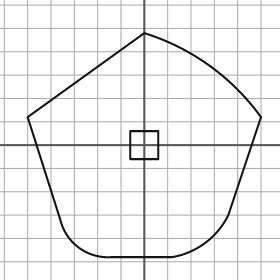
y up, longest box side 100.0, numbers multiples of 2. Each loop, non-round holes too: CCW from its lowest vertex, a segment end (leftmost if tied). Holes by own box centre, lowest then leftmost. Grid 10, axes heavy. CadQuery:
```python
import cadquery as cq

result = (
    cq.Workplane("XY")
    .moveTo(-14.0, -48.0)
    .lineTo(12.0, -48.0)
    .threePointArc((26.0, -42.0), (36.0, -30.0))
    .lineTo(50.0, 12.0)
    .threePointArc((28.0, 34.0), (0.0, 48.0))
    .lineTo(-50.0, 12.0)
    .lineTo(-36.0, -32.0)
    .threePointArc((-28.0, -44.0), (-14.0, -48.0))
    .close()
    .moveTo(-6.0, -6.0)
    .lineTo(6.0, -6.0)
    .lineTo(6.0, 6.0)
    .lineTo(-6.0, 6.0)
    .close()
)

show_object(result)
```